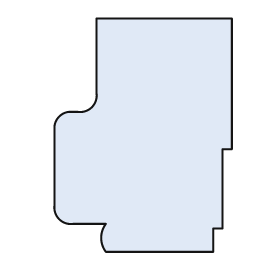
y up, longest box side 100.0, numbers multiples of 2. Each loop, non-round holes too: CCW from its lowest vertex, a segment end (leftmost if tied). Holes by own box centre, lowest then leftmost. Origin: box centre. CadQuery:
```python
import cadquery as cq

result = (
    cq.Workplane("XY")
    .moveTo(-16.0, -50.0)
    .lineTo(30.0, -50.0)
    .lineTo(30.0, -40.0)
    .lineTo(34.0, -40.0)
    .lineTo(34.0, -6.0)
    .lineTo(38.0, -6.0)
    .lineTo(38.0, 50.0)
    .lineTo(-20.0, 50.0)
    .lineTo(-20.0, 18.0)
    .threePointArc((-22.0, 12.0), (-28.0, 10.0))
    .lineTo(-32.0, 10.0)
    .threePointArc((-36.0, 8.0), (-38.0, 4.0))
    .lineTo(-38.0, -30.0)
    .threePointArc((-36.0, -36.0), (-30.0, -38.0))
    .lineTo(-16.0, -38.0)
    .threePointArc((-18.0, -44.0), (-16.0, -50.0))
    .close()
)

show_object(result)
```